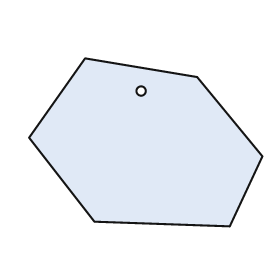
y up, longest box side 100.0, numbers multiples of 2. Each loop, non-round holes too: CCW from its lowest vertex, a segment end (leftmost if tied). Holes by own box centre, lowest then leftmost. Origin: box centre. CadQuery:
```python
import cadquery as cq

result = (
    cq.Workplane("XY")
    .moveTo(36.0, -36.0)
    .lineTo(50.0, -6.0)
    .lineTo(22.0, 28.0)
    .lineTo(-26.0, 36.0)
    .lineTo(-50.0, 2.0)
    .lineTo(-22.0, -34.0)
    .close()
    .moveTo(-2.0, 22.0)
    .circle(2.0)
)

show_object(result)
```